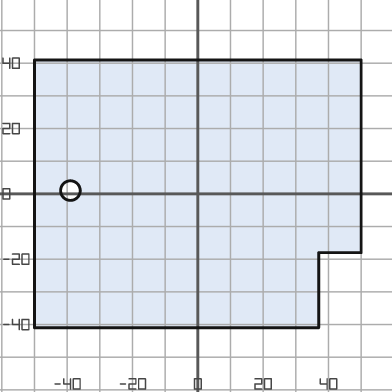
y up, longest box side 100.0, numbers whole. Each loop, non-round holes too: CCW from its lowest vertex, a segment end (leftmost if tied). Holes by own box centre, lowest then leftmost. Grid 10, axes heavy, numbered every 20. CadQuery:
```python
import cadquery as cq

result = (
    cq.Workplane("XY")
    .moveTo(-50.0, -41.0)
    .lineTo(37.0, -41.0)
    .lineTo(37.0, -18.0)
    .lineTo(50.0, -18.0)
    .lineTo(50.0, 41.0)
    .lineTo(-50.0, 41.0)
    .close()
    .moveTo(-39.0, 1.0)
    .circle(3.0)
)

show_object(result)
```